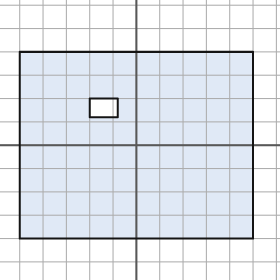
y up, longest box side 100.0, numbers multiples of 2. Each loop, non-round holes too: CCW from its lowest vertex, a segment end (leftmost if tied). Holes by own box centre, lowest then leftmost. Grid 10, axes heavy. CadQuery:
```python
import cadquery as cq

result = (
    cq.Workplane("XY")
    .moveTo(-50.0, -40.0)
    .lineTo(50.0, -40.0)
    .lineTo(50.0, 40.0)
    .lineTo(-50.0, 40.0)
    .close()
    .moveTo(-20.0, 12.0)
    .lineTo(-8.0, 12.0)
    .lineTo(-8.0, 20.0)
    .lineTo(-20.0, 20.0)
    .close()
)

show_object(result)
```